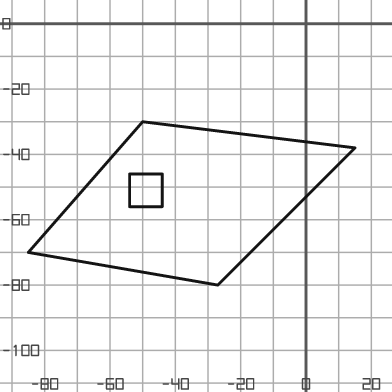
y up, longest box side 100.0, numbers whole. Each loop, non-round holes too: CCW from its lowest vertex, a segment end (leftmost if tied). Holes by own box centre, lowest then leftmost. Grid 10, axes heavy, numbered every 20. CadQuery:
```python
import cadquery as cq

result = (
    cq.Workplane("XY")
    .moveTo(-27.0, -80.0)
    .lineTo(15.0, -38.0)
    .lineTo(-50.0, -30.0)
    .lineTo(-85.0, -70.0)
    .close()
    .moveTo(-54.0, -56.0)
    .lineTo(-44.0, -56.0)
    .lineTo(-44.0, -46.0)
    .lineTo(-54.0, -46.0)
    .close()
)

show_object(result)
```